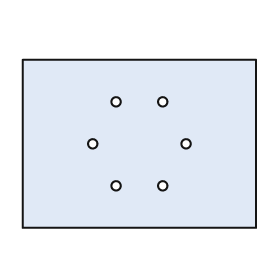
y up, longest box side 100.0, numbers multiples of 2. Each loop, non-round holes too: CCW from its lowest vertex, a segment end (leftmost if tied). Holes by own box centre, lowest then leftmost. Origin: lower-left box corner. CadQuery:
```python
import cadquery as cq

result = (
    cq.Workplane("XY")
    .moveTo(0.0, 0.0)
    .lineTo(100.0, 0.0)
    .lineTo(100.0, 72.0)
    .lineTo(0.0, 72.0)
    .close()
    .moveTo(40.0, 18.0)
    .circle(2.0)
    .moveTo(60.0, 18.0)
    .circle(2.0)
    .moveTo(30.0, 36.0)
    .circle(2.0)
    .moveTo(70.0, 36.0)
    .circle(2.0)
    .moveTo(40.0, 54.0)
    .circle(2.0)
    .moveTo(60.0, 54.0)
    .circle(2.0)
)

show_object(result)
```